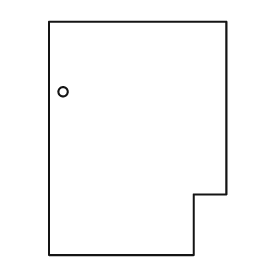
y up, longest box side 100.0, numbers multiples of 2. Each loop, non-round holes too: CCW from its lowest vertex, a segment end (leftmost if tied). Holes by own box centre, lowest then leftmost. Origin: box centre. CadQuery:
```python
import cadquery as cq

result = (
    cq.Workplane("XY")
    .moveTo(-38.0, -50.0)
    .lineTo(24.0, -50.0)
    .lineTo(24.0, -24.0)
    .lineTo(38.0, -24.0)
    .lineTo(38.0, 50.0)
    .lineTo(-38.0, 50.0)
    .close()
    .moveTo(-32.0, 20.0)
    .circle(2.0)
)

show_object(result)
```